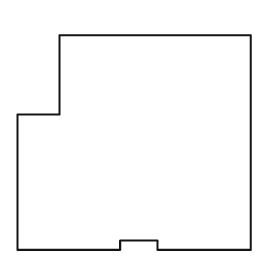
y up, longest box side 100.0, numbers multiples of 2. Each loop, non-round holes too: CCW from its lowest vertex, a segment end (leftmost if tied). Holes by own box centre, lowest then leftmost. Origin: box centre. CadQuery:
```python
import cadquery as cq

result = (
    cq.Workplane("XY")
    .moveTo(-50.0, -46.0)
    .lineTo(-6.0, -46.0)
    .lineTo(-6.0, -42.0)
    .lineTo(10.0, -42.0)
    .lineTo(10.0, -46.0)
    .lineTo(50.0, -46.0)
    .lineTo(50.0, 46.0)
    .lineTo(-32.0, 46.0)
    .lineTo(-32.0, 12.0)
    .lineTo(-50.0, 12.0)
    .close()
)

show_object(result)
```